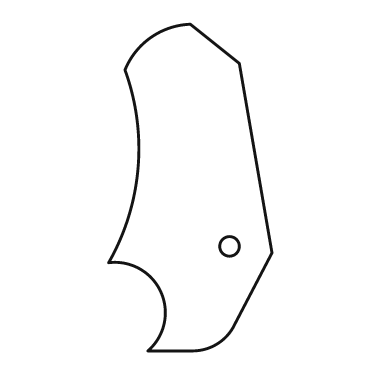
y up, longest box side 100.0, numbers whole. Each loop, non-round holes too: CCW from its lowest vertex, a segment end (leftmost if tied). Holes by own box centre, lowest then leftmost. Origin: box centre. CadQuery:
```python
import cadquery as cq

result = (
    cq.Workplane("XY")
    .moveTo(-13.0, -50.0)
    .lineTo(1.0, -50.0)
    .threePointArc((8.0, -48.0), (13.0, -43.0))
    .lineTo(25.0, -20.0)
    .lineTo(15.0, 38.0)
    .lineTo(0.0, 50.0)
    .threePointArc((-12.0, 46.0), (-20.0, 36.0))
    .threePointArc((-16.0, 6.0), (-25.0, -23.0))
    .threePointArc((-9.0, -32.0), (-13.0, -50.0))
    .close()
    .moveTo(12.0, -18.0)
    .circle(3.0)
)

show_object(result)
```